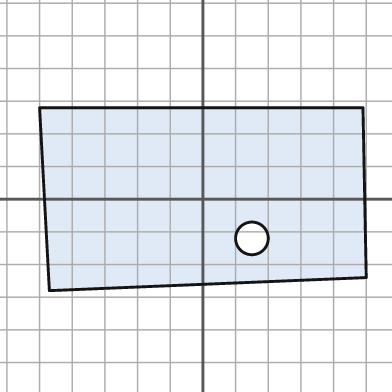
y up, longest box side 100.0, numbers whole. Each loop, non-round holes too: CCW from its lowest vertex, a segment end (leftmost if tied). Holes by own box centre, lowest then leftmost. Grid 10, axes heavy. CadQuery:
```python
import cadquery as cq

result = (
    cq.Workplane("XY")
    .moveTo(-47.0, -28.0)
    .lineTo(50.0, -24.0)
    .lineTo(49.0, 28.0)
    .lineTo(-50.0, 28.0)
    .close()
    .moveTo(15.0, -12.0)
    .circle(5.0)
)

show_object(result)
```